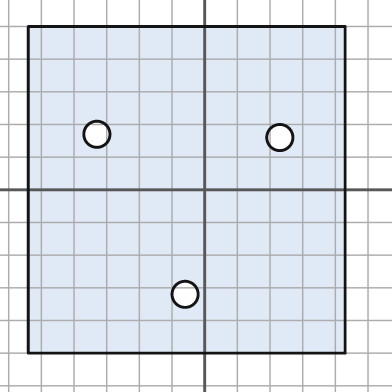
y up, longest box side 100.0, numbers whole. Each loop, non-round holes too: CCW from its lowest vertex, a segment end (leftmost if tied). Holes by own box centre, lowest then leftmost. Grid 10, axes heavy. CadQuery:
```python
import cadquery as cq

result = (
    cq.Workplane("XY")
    .moveTo(-54.0, -50.0)
    .lineTo(43.0, -50.0)
    .lineTo(43.0, 50.0)
    .lineTo(-54.0, 50.0)
    .close()
    .moveTo(-6.0, -32.0)
    .circle(4.0)
    .moveTo(23.0, 16.0)
    .circle(4.0)
    .moveTo(-33.0, 17.0)
    .circle(4.0)
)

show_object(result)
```